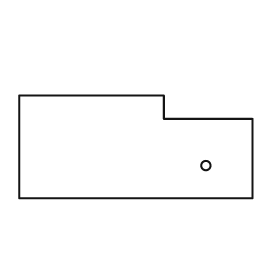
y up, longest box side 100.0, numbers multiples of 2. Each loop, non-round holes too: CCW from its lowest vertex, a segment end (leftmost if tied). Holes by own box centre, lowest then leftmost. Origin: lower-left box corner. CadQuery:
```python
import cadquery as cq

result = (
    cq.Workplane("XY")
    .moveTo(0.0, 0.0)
    .lineTo(100.0, 0.0)
    .lineTo(100.0, 34.0)
    .lineTo(62.0, 34.0)
    .lineTo(62.0, 44.0)
    .lineTo(0.0, 44.0)
    .close()
    .moveTo(80.0, 14.0)
    .circle(2.0)
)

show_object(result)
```